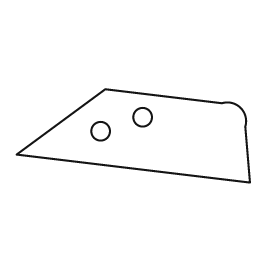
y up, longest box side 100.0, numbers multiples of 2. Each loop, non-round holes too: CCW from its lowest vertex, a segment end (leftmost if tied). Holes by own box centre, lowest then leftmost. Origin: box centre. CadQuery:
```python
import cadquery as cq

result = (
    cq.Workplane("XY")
    .moveTo(50.0, -20.0)
    .lineTo(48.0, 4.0)
    .threePointArc((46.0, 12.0), (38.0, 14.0))
    .lineTo(-12.0, 20.0)
    .lineTo(-50.0, -8.0)
    .close()
    .moveTo(-14.0, 2.0)
    .circle(4.0)
    .moveTo(4.0, 8.0)
    .circle(4.0)
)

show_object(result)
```